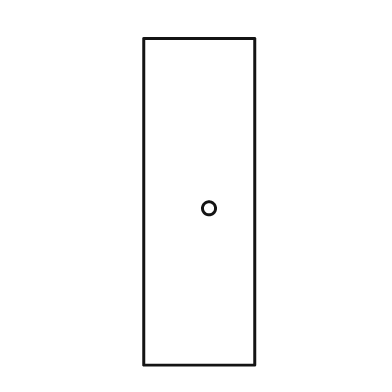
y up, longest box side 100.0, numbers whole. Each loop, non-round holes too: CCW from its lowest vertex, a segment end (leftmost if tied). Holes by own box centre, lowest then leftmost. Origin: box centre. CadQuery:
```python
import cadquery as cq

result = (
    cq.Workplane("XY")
    .moveTo(-17.0, -50.0)
    .lineTo(17.0, -50.0)
    .lineTo(17.0, 50.0)
    .lineTo(-17.0, 50.0)
    .close()
    .moveTo(3.0, -2.0)
    .circle(2.0)
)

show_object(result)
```